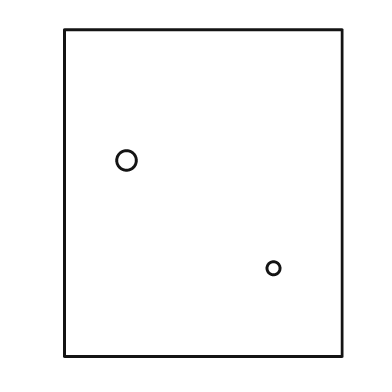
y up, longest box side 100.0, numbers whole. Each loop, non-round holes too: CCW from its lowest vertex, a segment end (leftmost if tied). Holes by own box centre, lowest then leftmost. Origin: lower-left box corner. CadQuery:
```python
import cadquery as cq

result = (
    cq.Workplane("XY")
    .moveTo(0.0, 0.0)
    .lineTo(85.0, 0.0)
    .lineTo(85.0, 100.0)
    .lineTo(0.0, 100.0)
    .close()
    .moveTo(64.0, 27.0)
    .circle(2.0)
    .moveTo(19.0, 60.0)
    .circle(3.0)
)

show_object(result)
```